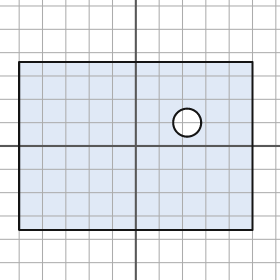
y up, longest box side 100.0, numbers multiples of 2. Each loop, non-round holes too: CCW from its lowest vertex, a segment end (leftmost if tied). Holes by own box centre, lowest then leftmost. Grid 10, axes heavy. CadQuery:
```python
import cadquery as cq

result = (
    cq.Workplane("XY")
    .moveTo(-50.0, -36.0)
    .lineTo(50.0, -36.0)
    .lineTo(50.0, 36.0)
    .lineTo(-50.0, 36.0)
    .close()
    .moveTo(22.0, 10.0)
    .circle(6.0)
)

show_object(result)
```